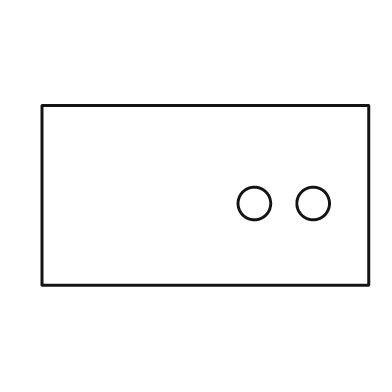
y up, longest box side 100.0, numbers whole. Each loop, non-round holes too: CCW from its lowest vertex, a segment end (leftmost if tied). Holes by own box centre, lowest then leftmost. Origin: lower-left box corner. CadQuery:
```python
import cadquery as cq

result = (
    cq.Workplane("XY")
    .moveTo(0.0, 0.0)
    .lineTo(100.0, 0.0)
    .lineTo(100.0, 55.0)
    .lineTo(0.0, 55.0)
    .close()
    .moveTo(65.0, 25.0)
    .circle(5.0)
    .moveTo(83.0, 25.0)
    .circle(5.0)
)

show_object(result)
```